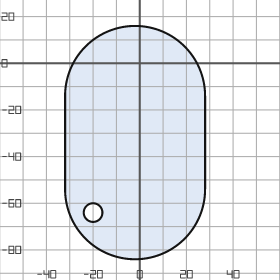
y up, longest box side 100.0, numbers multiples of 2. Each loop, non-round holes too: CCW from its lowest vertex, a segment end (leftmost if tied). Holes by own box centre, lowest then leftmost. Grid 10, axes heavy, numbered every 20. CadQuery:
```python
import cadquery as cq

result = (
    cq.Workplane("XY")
    .moveTo(-32.0, -54.0)
    .threePointArc((-2.0, -84.0), (28.0, -54.0))
    .lineTo(28.0, -14.0)
    .threePointArc((-2.0, 16.0), (-32.0, -14.0))
    .close()
    .moveTo(-20.0, -64.0)
    .circle(4.0)
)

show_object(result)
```